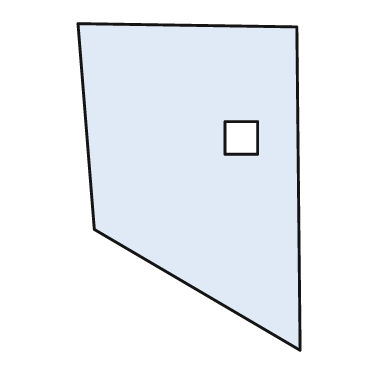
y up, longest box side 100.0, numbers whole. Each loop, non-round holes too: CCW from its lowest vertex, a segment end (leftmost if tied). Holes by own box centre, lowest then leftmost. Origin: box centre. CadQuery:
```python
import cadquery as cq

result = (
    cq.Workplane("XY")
    .moveTo(34.0, -50.0)
    .lineTo(33.0, 49.0)
    .lineTo(-34.0, 50.0)
    .lineTo(-29.0, -13.0)
    .close()
    .moveTo(11.0, 10.0)
    .lineTo(21.0, 10.0)
    .lineTo(21.0, 20.0)
    .lineTo(11.0, 20.0)
    .close()
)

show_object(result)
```